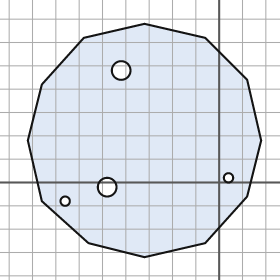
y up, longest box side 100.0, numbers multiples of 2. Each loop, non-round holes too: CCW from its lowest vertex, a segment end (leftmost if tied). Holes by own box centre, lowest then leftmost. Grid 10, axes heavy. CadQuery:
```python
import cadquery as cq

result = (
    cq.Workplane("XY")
    .moveTo(-32.0, -32.0)
    .lineTo(-6.0, -26.0)
    .lineTo(12.0, -6.0)
    .lineTo(18.0, 18.0)
    .lineTo(12.0, 44.0)
    .lineTo(-6.0, 62.0)
    .lineTo(-32.0, 68.0)
    .lineTo(-58.0, 62.0)
    .lineTo(-76.0, 42.0)
    .lineTo(-82.0, 18.0)
    .lineTo(-76.0, -8.0)
    .lineTo(-56.0, -26.0)
    .close()
    .moveTo(-66.0, -8.0)
    .circle(2.0)
    .moveTo(-48.0, -2.0)
    .circle(4.0)
    .moveTo(4.0, 2.0)
    .circle(2.0)
    .moveTo(-42.0, 48.0)
    .circle(4.0)
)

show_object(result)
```